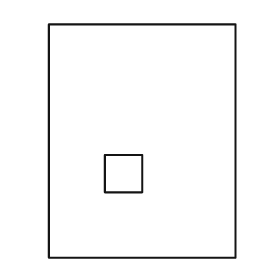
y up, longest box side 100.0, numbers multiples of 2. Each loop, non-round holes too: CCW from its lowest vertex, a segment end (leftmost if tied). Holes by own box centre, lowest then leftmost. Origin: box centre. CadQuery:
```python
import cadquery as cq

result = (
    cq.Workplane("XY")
    .moveTo(-40.0, -50.0)
    .lineTo(40.0, -50.0)
    .lineTo(40.0, 50.0)
    .lineTo(-40.0, 50.0)
    .close()
    .moveTo(-16.0, -22.0)
    .lineTo(0.0, -22.0)
    .lineTo(0.0, -6.0)
    .lineTo(-16.0, -6.0)
    .close()
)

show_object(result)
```